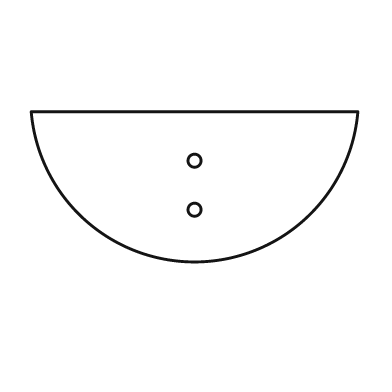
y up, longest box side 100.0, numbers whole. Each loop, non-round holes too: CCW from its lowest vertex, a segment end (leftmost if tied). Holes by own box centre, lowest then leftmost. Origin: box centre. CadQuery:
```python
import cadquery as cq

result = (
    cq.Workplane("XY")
    .moveTo(-50.0, 23.0)
    .threePointArc((0.0, -23.0), (50.0, 23.0))
    .close()
    .moveTo(0.0, -7.0)
    .circle(2.0)
    .moveTo(0.0, 8.0)
    .circle(2.0)
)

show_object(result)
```